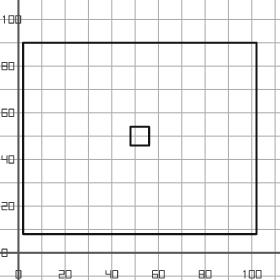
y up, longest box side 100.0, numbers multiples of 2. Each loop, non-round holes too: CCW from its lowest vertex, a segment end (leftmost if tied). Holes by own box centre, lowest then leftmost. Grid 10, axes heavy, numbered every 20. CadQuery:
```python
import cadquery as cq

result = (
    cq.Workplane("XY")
    .moveTo(2.0, 8.0)
    .lineTo(102.0, 8.0)
    .lineTo(102.0, 90.0)
    .lineTo(2.0, 90.0)
    .close()
    .moveTo(48.0, 46.0)
    .lineTo(56.0, 46.0)
    .lineTo(56.0, 54.0)
    .lineTo(48.0, 54.0)
    .close()
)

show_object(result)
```